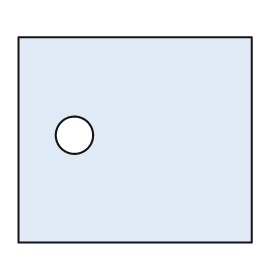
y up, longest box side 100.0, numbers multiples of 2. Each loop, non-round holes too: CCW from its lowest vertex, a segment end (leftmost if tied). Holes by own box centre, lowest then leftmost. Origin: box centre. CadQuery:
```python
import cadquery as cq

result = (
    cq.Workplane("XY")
    .moveTo(-50.0, -44.0)
    .lineTo(50.0, -44.0)
    .lineTo(50.0, 44.0)
    .lineTo(-50.0, 44.0)
    .close()
    .moveTo(-26.0, 2.0)
    .circle(8.0)
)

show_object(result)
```